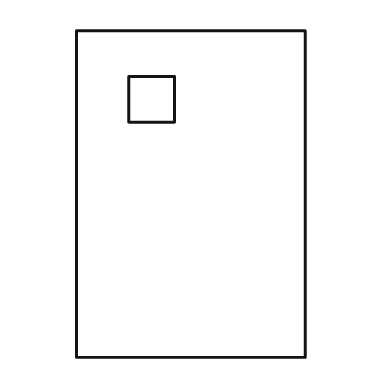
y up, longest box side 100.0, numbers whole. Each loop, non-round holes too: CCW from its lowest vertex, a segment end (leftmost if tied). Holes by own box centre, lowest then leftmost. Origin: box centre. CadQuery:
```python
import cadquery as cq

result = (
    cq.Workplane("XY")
    .moveTo(-35.0, -50.0)
    .lineTo(35.0, -50.0)
    .lineTo(35.0, 50.0)
    .lineTo(-35.0, 50.0)
    .close()
    .moveTo(-19.0, 22.0)
    .lineTo(-5.0, 22.0)
    .lineTo(-5.0, 36.0)
    .lineTo(-19.0, 36.0)
    .close()
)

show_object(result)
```